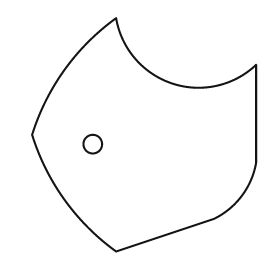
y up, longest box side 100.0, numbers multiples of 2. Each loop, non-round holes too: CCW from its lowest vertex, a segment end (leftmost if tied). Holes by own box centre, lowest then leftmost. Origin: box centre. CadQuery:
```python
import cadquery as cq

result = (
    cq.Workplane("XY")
    .moveTo(-12.0, -50.0)
    .lineTo(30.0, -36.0)
    .threePointArc((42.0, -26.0), (48.0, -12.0))
    .lineTo(48.0, 30.0)
    .threePointArc((12.0, 22.0), (-12.0, 50.0))
    .threePointArc((-34.0, 28.0), (-48.0, 0.0))
    .threePointArc((-34.0, -28.0), (-12.0, -50.0))
    .close()
    .moveTo(-22.0, -4.0)
    .circle(4.0)
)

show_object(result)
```